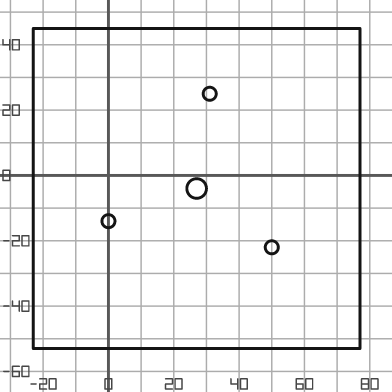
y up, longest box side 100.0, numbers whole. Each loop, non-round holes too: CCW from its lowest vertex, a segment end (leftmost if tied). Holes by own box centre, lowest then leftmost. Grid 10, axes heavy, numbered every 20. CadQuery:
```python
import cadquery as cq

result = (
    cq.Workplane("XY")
    .moveTo(-23.0, -53.0)
    .lineTo(77.0, -53.0)
    .lineTo(77.0, 45.0)
    .lineTo(-23.0, 45.0)
    .close()
    .moveTo(50.0, -22.0)
    .circle(2.0)
    .moveTo(0.0, -14.0)
    .circle(2.0)
    .moveTo(27.0, -4.0)
    .circle(3.0)
    .moveTo(31.0, 25.0)
    .circle(2.0)
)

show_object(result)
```